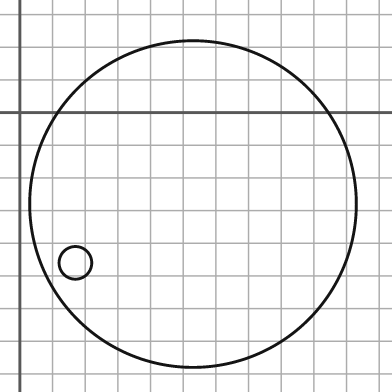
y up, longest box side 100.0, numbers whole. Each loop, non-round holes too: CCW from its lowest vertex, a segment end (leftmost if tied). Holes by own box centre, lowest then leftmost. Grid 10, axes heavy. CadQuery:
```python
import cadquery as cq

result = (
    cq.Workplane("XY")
    .moveTo(53.0, -28.0)
    .circle(50.0)
    .moveTo(17.0, -46.0)
    .circle(5.0)
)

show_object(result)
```